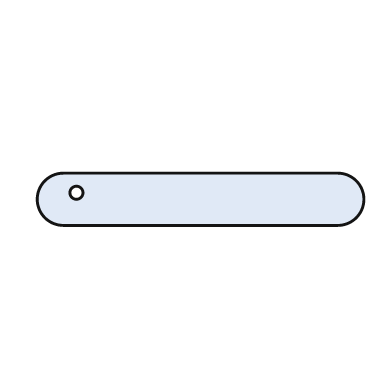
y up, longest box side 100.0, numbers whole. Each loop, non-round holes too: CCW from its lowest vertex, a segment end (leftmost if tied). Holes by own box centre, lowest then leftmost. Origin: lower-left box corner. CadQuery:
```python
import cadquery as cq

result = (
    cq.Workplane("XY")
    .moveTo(8.0, 0.0)
    .lineTo(92.0, 0.0)
    .threePointArc((100.0, 8.0), (92.0, 16.0))
    .lineTo(8.0, 16.0)
    .threePointArc((0.0, 8.0), (8.0, 0.0))
    .close()
    .moveTo(12.0, 10.0)
    .circle(2.0)
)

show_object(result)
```